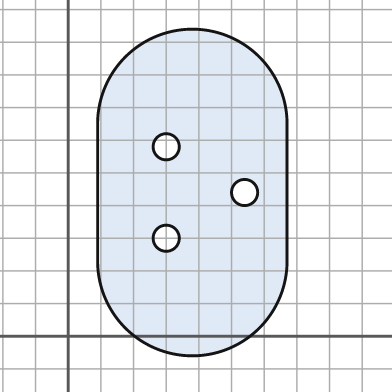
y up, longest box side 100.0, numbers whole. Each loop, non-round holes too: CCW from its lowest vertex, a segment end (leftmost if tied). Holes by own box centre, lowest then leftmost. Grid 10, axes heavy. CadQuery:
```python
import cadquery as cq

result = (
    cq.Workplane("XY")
    .moveTo(9.0, 23.0)
    .threePointArc((38.0, -6.0), (67.0, 23.0))
    .lineTo(67.0, 65.0)
    .threePointArc((38.0, 94.0), (9.0, 65.0))
    .close()
    .moveTo(30.0, 30.0)
    .circle(4.0)
    .moveTo(54.0, 44.0)
    .circle(4.0)
    .moveTo(30.0, 58.0)
    .circle(4.0)
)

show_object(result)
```